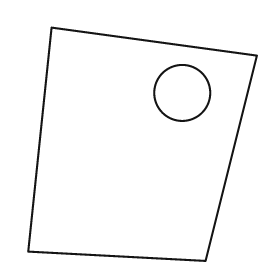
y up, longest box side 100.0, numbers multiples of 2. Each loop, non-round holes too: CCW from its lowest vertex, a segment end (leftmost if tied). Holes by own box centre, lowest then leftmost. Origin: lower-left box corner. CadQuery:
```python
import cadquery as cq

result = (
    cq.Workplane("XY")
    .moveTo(76.0, 0.0)
    .lineTo(98.0, 88.0)
    .lineTo(10.0, 100.0)
    .lineTo(0.0, 4.0)
    .close()
    .moveTo(66.0, 72.0)
    .circle(12.0)
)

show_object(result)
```